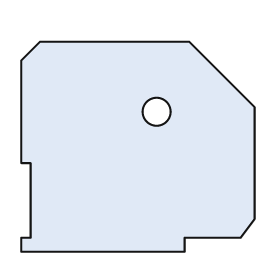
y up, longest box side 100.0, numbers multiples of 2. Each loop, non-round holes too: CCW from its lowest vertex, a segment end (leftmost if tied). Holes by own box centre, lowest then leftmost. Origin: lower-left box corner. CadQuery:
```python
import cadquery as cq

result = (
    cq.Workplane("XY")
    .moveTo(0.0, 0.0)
    .lineTo(70.0, 0.0)
    .lineTo(70.0, 6.0)
    .lineTo(94.0, 6.0)
    .lineTo(100.0, 14.0)
    .lineTo(100.0, 62.0)
    .lineTo(72.0, 90.0)
    .lineTo(8.0, 90.0)
    .lineTo(0.0, 82.0)
    .lineTo(0.0, 38.0)
    .lineTo(4.0, 38.0)
    .lineTo(4.0, 6.0)
    .lineTo(0.0, 6.0)
    .close()
    .moveTo(58.0, 60.0)
    .circle(6.0)
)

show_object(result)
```